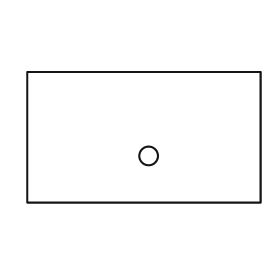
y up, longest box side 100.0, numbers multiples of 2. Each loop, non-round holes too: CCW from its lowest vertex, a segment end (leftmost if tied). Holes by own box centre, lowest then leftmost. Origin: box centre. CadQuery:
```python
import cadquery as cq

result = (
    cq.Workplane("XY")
    .moveTo(-50.0, -28.0)
    .lineTo(50.0, -28.0)
    .lineTo(50.0, 28.0)
    .lineTo(-50.0, 28.0)
    .close()
    .moveTo(2.0, -8.0)
    .circle(4.0)
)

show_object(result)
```